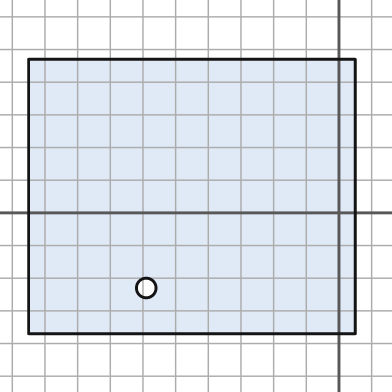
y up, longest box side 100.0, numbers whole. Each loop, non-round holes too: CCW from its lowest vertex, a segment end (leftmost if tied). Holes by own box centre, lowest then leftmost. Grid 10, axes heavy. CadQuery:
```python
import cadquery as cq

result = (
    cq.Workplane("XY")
    .moveTo(-95.0, -37.0)
    .lineTo(5.0, -37.0)
    .lineTo(5.0, 47.0)
    .lineTo(-95.0, 47.0)
    .close()
    .moveTo(-59.0, -23.0)
    .circle(3.0)
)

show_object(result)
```